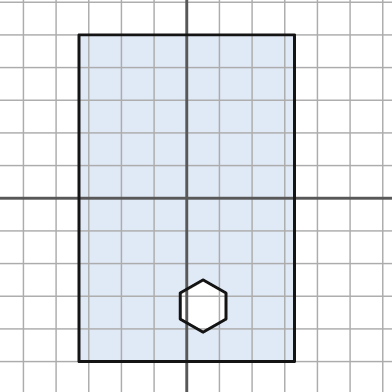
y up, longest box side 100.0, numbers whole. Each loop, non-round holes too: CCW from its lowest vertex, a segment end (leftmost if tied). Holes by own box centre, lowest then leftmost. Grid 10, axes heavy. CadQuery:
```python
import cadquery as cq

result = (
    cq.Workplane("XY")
    .moveTo(-33.0, -50.0)
    .lineTo(33.0, -50.0)
    .lineTo(33.0, 50.0)
    .lineTo(-33.0, 50.0)
    .close()
    .moveTo(5.0, -41.0)
    .lineTo(12.0, -37.0)
    .lineTo(12.0, -29.0)
    .lineTo(5.0, -25.0)
    .lineTo(-2.0, -29.0)
    .lineTo(-2.0, -37.0)
    .close()
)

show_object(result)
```